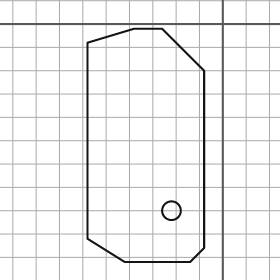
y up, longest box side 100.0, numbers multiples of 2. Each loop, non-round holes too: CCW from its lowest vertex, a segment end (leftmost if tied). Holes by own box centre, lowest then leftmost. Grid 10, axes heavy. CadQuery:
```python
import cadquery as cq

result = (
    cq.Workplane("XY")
    .moveTo(-42.0, -102.0)
    .lineTo(-14.0, -102.0)
    .lineTo(-8.0, -96.0)
    .lineTo(-8.0, -20.0)
    .lineTo(-26.0, -2.0)
    .lineTo(-38.0, -2.0)
    .lineTo(-58.0, -8.0)
    .lineTo(-58.0, -92.0)
    .close()
    .moveTo(-22.0, -80.0)
    .circle(4.0)
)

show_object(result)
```